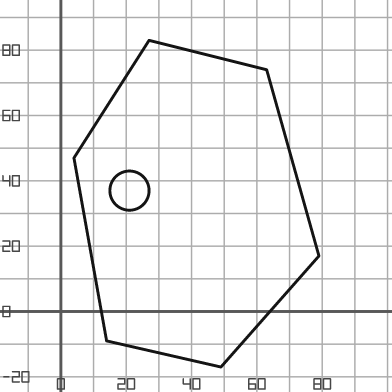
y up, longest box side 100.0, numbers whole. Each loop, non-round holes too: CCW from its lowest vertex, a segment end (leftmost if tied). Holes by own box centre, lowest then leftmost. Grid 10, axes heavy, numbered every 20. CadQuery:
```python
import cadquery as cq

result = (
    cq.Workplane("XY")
    .moveTo(49.0, -17.0)
    .lineTo(79.0, 17.0)
    .lineTo(63.0, 74.0)
    .lineTo(27.0, 83.0)
    .lineTo(4.0, 47.0)
    .lineTo(14.0, -9.0)
    .close()
    .moveTo(21.0, 37.0)
    .circle(6.0)
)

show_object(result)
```